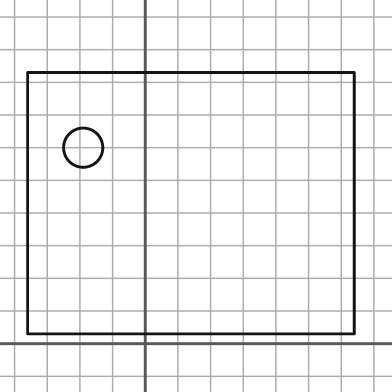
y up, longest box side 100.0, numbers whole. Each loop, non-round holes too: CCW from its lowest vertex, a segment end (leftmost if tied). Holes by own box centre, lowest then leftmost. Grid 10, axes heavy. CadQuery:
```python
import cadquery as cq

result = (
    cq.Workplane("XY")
    .moveTo(-36.0, 3.0)
    .lineTo(64.0, 3.0)
    .lineTo(64.0, 83.0)
    .lineTo(-36.0, 83.0)
    .close()
    .moveTo(-19.0, 60.0)
    .circle(6.0)
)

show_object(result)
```